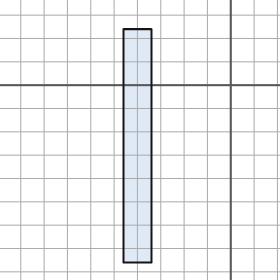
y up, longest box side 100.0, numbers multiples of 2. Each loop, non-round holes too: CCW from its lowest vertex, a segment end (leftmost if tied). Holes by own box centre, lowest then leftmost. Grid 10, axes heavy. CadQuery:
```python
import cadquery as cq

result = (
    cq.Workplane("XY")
    .moveTo(-46.0, -76.0)
    .lineTo(-34.0, -76.0)
    .lineTo(-34.0, 24.0)
    .lineTo(-46.0, 24.0)
    .close()
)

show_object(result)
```